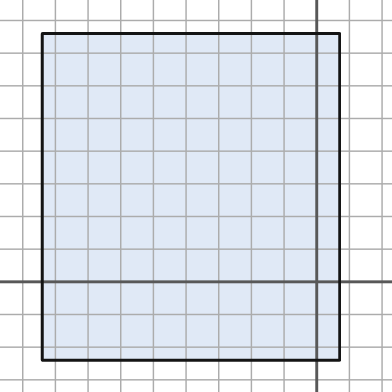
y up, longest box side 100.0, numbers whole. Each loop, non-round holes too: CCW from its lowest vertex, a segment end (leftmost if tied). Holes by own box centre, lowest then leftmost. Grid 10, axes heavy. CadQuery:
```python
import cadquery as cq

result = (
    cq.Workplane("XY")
    .moveTo(-84.0, -24.0)
    .lineTo(7.0, -24.0)
    .lineTo(7.0, 76.0)
    .lineTo(-84.0, 76.0)
    .close()
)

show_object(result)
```